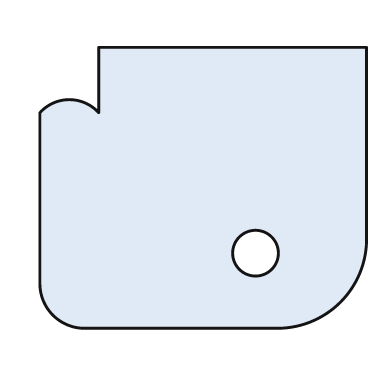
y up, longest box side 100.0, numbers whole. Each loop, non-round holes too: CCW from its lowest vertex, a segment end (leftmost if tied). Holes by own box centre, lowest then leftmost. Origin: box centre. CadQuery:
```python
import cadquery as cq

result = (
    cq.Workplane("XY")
    .moveTo(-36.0, -43.0)
    .lineTo(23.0, -43.0)
    .threePointArc((42.0, -35.0), (50.0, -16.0))
    .lineTo(50.0, 43.0)
    .lineTo(-32.0, 43.0)
    .lineTo(-32.0, 23.0)
    .threePointArc((-41.0, 27.0), (-50.0, 23.0))
    .lineTo(-50.0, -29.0)
    .threePointArc((-46.0, -39.0), (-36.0, -43.0))
    .close()
    .moveTo(16.0, -20.0)
    .circle(7.0)
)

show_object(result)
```